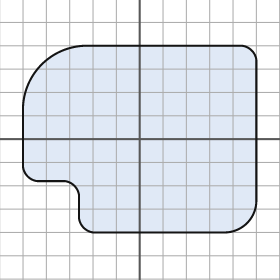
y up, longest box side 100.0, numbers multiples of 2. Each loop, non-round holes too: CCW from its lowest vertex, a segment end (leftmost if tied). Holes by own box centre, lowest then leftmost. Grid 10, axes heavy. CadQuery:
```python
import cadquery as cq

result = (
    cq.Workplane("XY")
    .moveTo(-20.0, -40.0)
    .lineTo(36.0, -40.0)
    .threePointArc((46.0, -36.0), (50.0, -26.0))
    .lineTo(50.0, 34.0)
    .threePointArc((48.0, 38.0), (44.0, 40.0))
    .lineTo(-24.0, 40.0)
    .threePointArc((-42.0, 32.0), (-50.0, 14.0))
    .lineTo(-50.0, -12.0)
    .threePointArc((-48.0, -16.0), (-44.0, -18.0))
    .lineTo(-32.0, -18.0)
    .threePointArc((-28.0, -20.0), (-26.0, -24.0))
    .lineTo(-26.0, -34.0)
    .threePointArc((-24.0, -38.0), (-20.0, -40.0))
    .close()
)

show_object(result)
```